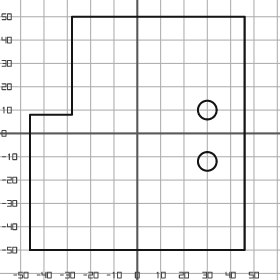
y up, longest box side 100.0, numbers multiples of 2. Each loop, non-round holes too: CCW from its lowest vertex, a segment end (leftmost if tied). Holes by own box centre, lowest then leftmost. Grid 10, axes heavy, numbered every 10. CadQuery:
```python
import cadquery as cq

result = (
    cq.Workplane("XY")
    .moveTo(-46.0, -50.0)
    .lineTo(46.0, -50.0)
    .lineTo(46.0, 50.0)
    .lineTo(-28.0, 50.0)
    .lineTo(-28.0, 8.0)
    .lineTo(-46.0, 8.0)
    .close()
    .moveTo(30.0, -12.0)
    .circle(4.0)
    .moveTo(30.0, 10.0)
    .circle(4.0)
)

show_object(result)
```